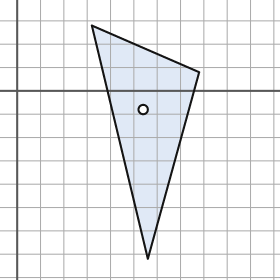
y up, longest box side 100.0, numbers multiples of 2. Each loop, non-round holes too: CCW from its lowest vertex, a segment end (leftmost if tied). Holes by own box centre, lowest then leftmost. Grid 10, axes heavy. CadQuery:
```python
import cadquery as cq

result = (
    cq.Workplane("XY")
    .moveTo(56.0, -72.0)
    .lineTo(78.0, 8.0)
    .lineTo(32.0, 28.0)
    .close()
    .moveTo(54.0, -8.0)
    .circle(2.0)
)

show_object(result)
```